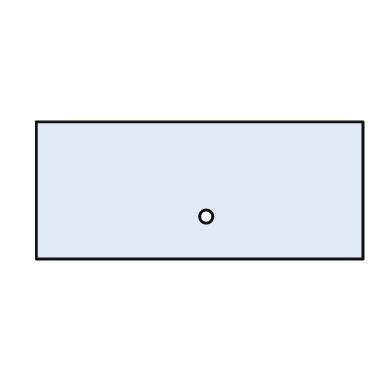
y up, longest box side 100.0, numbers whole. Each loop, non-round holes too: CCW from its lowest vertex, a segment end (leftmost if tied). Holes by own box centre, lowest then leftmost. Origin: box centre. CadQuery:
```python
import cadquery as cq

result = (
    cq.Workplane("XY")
    .moveTo(-50.0, -21.0)
    .lineTo(50.0, -21.0)
    .lineTo(50.0, 21.0)
    .lineTo(-50.0, 21.0)
    .close()
    .moveTo(2.0, -8.0)
    .circle(2.0)
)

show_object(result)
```